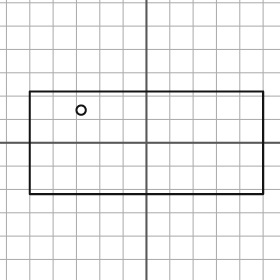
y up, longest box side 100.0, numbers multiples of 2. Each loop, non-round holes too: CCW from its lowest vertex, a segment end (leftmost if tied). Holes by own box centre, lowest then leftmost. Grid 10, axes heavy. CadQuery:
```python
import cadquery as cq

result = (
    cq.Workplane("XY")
    .moveTo(-50.0, -22.0)
    .lineTo(50.0, -22.0)
    .lineTo(50.0, 22.0)
    .lineTo(-50.0, 22.0)
    .close()
    .moveTo(-28.0, 14.0)
    .circle(2.0)
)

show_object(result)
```